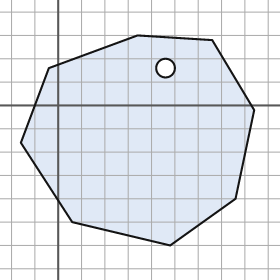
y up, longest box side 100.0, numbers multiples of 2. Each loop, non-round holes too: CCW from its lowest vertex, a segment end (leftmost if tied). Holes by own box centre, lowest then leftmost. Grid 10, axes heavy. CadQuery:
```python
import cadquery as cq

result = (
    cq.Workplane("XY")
    .moveTo(48.0, -60.0)
    .lineTo(76.0, -40.0)
    .lineTo(84.0, -2.0)
    .lineTo(66.0, 28.0)
    .lineTo(34.0, 30.0)
    .lineTo(-4.0, 16.0)
    .lineTo(-16.0, -16.0)
    .lineTo(6.0, -50.0)
    .close()
    .moveTo(46.0, 16.0)
    .circle(4.0)
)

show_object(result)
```